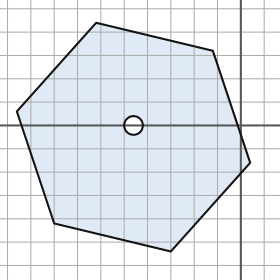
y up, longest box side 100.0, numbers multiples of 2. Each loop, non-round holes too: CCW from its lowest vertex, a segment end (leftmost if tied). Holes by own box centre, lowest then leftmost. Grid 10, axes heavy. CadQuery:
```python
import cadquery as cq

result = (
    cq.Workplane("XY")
    .moveTo(-30.0, -54.0)
    .lineTo(4.0, -16.0)
    .lineTo(-12.0, 32.0)
    .lineTo(-62.0, 44.0)
    .lineTo(-96.0, 6.0)
    .lineTo(-80.0, -42.0)
    .close()
    .moveTo(-46.0, 0.0)
    .circle(4.0)
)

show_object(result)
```